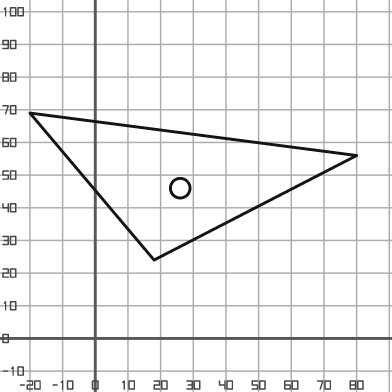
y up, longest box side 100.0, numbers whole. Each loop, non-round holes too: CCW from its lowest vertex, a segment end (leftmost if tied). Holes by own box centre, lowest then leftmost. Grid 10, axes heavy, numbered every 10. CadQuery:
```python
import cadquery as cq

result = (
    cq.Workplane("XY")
    .moveTo(18.0, 24.0)
    .lineTo(80.0, 56.0)
    .lineTo(-20.0, 69.0)
    .close()
    .moveTo(26.0, 46.0)
    .circle(3.0)
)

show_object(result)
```